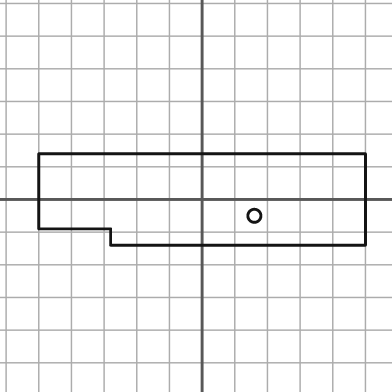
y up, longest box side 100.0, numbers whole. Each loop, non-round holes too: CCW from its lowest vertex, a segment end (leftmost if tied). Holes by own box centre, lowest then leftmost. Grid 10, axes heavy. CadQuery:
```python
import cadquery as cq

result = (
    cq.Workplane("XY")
    .moveTo(-28.0, -14.0)
    .lineTo(50.0, -14.0)
    .lineTo(50.0, 14.0)
    .lineTo(-50.0, 14.0)
    .lineTo(-50.0, -9.0)
    .lineTo(-28.0, -9.0)
    .close()
    .moveTo(16.0, -5.0)
    .circle(2.0)
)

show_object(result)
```